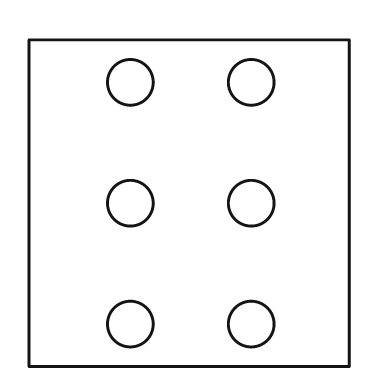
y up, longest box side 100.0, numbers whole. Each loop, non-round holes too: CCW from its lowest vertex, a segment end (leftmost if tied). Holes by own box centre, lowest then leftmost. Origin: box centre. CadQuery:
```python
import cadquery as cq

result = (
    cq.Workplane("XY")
    .moveTo(-49.0, -50.0)
    .lineTo(49.0, -50.0)
    .lineTo(49.0, 50.0)
    .lineTo(-49.0, 50.0)
    .close()
    .moveTo(-18.0, -37.0)
    .circle(7.0)
    .moveTo(19.0, -37.0)
    .circle(7.0)
    .moveTo(-18.0, 0.0)
    .circle(7.0)
    .moveTo(19.0, 0.0)
    .circle(7.0)
    .moveTo(-18.0, 37.0)
    .circle(7.0)
    .moveTo(19.0, 37.0)
    .circle(7.0)
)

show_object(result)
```